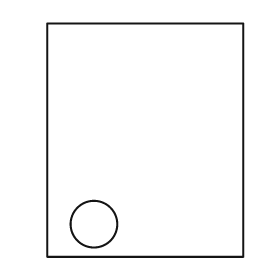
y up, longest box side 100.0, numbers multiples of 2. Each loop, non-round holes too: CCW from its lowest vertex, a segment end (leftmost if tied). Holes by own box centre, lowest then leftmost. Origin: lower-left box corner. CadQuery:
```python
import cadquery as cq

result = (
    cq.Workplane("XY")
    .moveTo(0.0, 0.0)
    .lineTo(84.0, 0.0)
    .lineTo(84.0, 100.0)
    .lineTo(0.0, 100.0)
    .close()
    .moveTo(20.0, 14.0)
    .circle(10.0)
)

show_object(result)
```